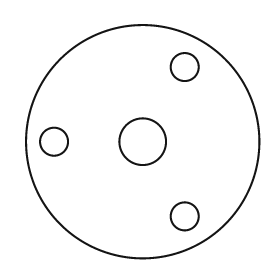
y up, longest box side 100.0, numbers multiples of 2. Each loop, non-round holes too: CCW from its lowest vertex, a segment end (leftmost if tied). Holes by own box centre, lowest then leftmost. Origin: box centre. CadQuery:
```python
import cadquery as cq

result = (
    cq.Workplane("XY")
    .moveTo(0.0, 0.0)
    .circle(50.0)
    .moveTo(18.0, -32.0)
    .circle(6.0)
    .moveTo(-38.0, 0.0)
    .circle(6.0)
    .moveTo(0.0, 0.0)
    .circle(10.0)
    .moveTo(18.0, 32.0)
    .circle(6.0)
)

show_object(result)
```